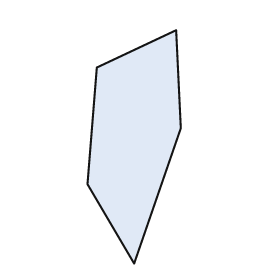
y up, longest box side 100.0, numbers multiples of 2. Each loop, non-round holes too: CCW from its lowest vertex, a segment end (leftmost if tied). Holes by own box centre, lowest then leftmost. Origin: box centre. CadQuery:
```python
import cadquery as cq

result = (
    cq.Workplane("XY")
    .moveTo(0.0, -50.0)
    .lineTo(20.0, 8.0)
    .lineTo(18.0, 50.0)
    .lineTo(-16.0, 34.0)
    .lineTo(-20.0, -16.0)
    .close()
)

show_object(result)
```